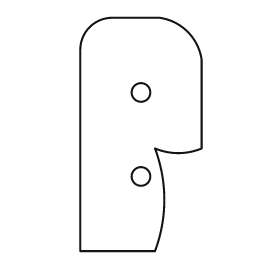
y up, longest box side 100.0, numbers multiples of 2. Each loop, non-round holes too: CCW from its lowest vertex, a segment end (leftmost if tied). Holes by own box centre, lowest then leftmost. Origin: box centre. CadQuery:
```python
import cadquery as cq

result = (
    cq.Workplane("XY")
    .moveTo(-26.0, -50.0)
    .lineTo(6.0, -50.0)
    .threePointArc((10.0, -28.0), (6.0, -6.0))
    .threePointArc((16.0, -8.0), (26.0, -6.0))
    .lineTo(26.0, 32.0)
    .threePointArc((20.0, 44.0), (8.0, 50.0))
    .lineTo(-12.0, 50.0)
    .threePointArc((-22.0, 46.0), (-26.0, 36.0))
    .close()
    .moveTo(0.0, -18.0)
    .circle(4.0)
    .moveTo(0.0, 18.0)
    .circle(4.0)
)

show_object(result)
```